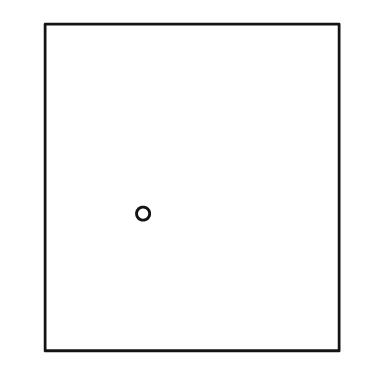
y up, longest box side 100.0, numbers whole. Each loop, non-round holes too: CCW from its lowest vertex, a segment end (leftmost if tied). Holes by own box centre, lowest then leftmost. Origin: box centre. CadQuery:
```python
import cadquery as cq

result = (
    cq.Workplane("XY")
    .moveTo(-45.0, -50.0)
    .lineTo(45.0, -50.0)
    .lineTo(45.0, 50.0)
    .lineTo(-45.0, 50.0)
    .close()
    .moveTo(-15.0, -8.0)
    .circle(2.0)
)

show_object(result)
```